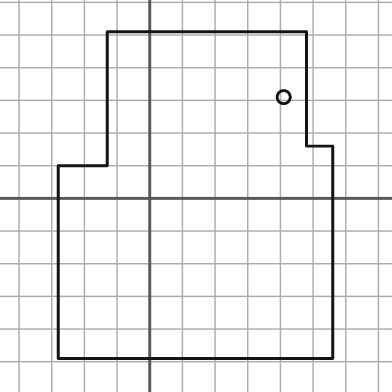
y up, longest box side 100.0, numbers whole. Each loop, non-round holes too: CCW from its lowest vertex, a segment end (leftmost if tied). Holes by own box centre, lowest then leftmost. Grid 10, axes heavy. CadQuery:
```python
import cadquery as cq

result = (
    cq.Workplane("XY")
    .moveTo(-28.0, -49.0)
    .lineTo(56.0, -49.0)
    .lineTo(56.0, 16.0)
    .lineTo(48.0, 16.0)
    .lineTo(48.0, 51.0)
    .lineTo(-13.0, 51.0)
    .lineTo(-13.0, 10.0)
    .lineTo(-28.0, 10.0)
    .close()
    .moveTo(41.0, 31.0)
    .circle(2.0)
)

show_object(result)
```